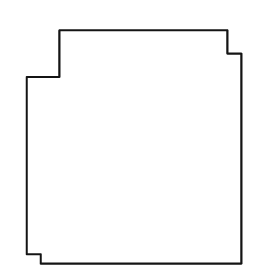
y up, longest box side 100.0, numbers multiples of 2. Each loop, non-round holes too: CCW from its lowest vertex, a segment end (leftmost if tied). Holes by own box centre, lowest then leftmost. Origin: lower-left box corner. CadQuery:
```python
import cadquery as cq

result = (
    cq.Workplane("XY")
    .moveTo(6.0, 0.0)
    .lineTo(92.0, 0.0)
    .lineTo(92.0, 90.0)
    .lineTo(86.0, 90.0)
    .lineTo(86.0, 100.0)
    .lineTo(14.0, 100.0)
    .lineTo(14.0, 80.0)
    .lineTo(0.0, 80.0)
    .lineTo(0.0, 4.0)
    .lineTo(6.0, 4.0)
    .close()
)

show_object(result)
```